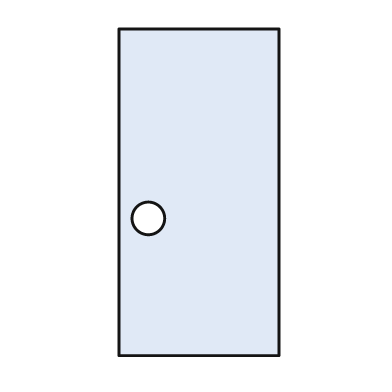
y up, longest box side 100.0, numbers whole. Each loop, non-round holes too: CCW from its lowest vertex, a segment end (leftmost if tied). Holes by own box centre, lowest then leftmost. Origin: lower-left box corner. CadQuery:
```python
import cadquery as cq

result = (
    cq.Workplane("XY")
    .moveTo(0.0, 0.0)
    .lineTo(49.0, 0.0)
    .lineTo(49.0, 100.0)
    .lineTo(0.0, 100.0)
    .close()
    .moveTo(9.0, 42.0)
    .circle(5.0)
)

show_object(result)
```